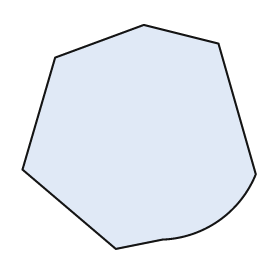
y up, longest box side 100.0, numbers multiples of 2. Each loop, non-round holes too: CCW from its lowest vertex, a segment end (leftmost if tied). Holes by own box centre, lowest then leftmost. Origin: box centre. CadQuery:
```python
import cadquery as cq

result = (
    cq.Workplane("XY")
    .moveTo(-10.0, -48.0)
    .lineTo(10.0, -44.0)
    .threePointArc((34.0, -36.0), (50.0, -16.0))
    .lineTo(34.0, 40.0)
    .lineTo(2.0, 48.0)
    .lineTo(-36.0, 34.0)
    .lineTo(-50.0, -14.0)
    .close()
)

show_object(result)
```